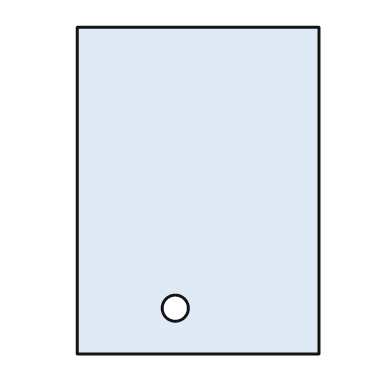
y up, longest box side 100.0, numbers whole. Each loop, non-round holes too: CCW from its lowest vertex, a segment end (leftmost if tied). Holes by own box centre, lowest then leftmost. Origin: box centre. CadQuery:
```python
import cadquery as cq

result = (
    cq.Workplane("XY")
    .moveTo(-37.0, -50.0)
    .lineTo(37.0, -50.0)
    .lineTo(37.0, 50.0)
    .lineTo(-37.0, 50.0)
    .close()
    .moveTo(-7.0, -36.0)
    .circle(4.0)
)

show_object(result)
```